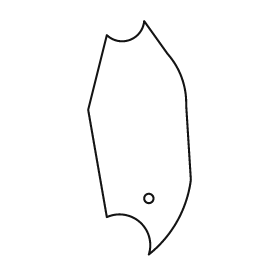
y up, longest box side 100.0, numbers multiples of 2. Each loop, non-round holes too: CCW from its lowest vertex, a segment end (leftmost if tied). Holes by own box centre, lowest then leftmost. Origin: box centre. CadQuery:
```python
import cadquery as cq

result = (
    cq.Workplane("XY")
    .moveTo(4.0, -50.0)
    .threePointArc((16.0, -36.0), (22.0, -18.0))
    .lineTo(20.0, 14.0)
    .threePointArc((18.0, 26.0), (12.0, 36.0))
    .lineTo(2.0, 50.0)
    .threePointArc((-4.0, 42.0), (-14.0, 44.0))
    .lineTo(-22.0, 12.0)
    .lineTo(-14.0, -34.0)
    .threePointArc((0.0, -36.0), (4.0, -50.0))
    .close()
    .moveTo(4.0, -26.0)
    .circle(2.0)
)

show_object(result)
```